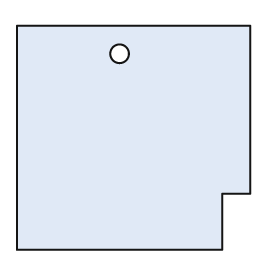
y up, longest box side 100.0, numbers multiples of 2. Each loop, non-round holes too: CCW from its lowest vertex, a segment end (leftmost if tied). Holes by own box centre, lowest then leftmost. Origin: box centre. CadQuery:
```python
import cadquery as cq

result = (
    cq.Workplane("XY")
    .moveTo(-50.0, -48.0)
    .lineTo(38.0, -48.0)
    .lineTo(38.0, -24.0)
    .lineTo(50.0, -24.0)
    .lineTo(50.0, 48.0)
    .lineTo(-50.0, 48.0)
    .close()
    .moveTo(-6.0, 36.0)
    .circle(4.0)
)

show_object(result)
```